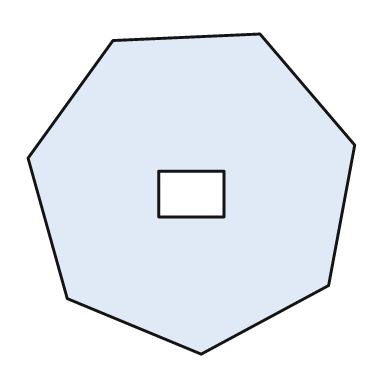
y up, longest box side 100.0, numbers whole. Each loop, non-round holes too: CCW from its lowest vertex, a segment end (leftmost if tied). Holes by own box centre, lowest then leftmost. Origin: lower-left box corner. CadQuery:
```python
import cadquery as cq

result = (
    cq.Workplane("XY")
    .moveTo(53.0, 0.0)
    .lineTo(92.0, 21.0)
    .lineTo(100.0, 64.0)
    .lineTo(71.0, 98.0)
    .lineTo(26.0, 96.0)
    .lineTo(0.0, 60.0)
    .lineTo(12.0, 17.0)
    .close()
    .moveTo(40.0, 42.0)
    .lineTo(60.0, 42.0)
    .lineTo(60.0, 56.0)
    .lineTo(40.0, 56.0)
    .close()
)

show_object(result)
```